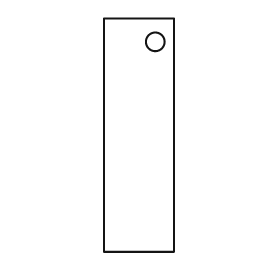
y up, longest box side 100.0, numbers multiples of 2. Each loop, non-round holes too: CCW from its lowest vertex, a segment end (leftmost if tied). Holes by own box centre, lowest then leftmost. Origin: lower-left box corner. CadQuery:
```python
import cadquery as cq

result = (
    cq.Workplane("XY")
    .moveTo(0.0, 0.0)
    .lineTo(30.0, 0.0)
    .lineTo(30.0, 100.0)
    .lineTo(0.0, 100.0)
    .close()
    .moveTo(22.0, 90.0)
    .circle(4.0)
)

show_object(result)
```